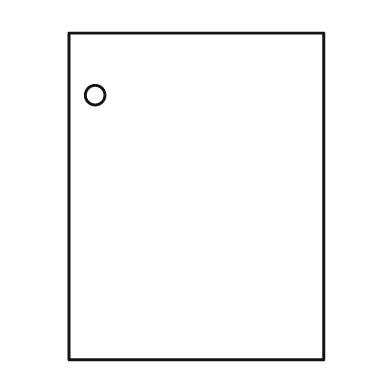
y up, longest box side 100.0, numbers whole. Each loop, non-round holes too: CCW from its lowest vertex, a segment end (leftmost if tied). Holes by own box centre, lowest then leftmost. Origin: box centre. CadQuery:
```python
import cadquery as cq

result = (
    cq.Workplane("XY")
    .moveTo(-39.0, -50.0)
    .lineTo(39.0, -50.0)
    .lineTo(39.0, 50.0)
    .lineTo(-39.0, 50.0)
    .close()
    .moveTo(-31.0, 31.0)
    .circle(3.0)
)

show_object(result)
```